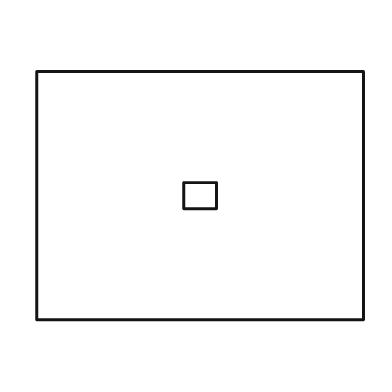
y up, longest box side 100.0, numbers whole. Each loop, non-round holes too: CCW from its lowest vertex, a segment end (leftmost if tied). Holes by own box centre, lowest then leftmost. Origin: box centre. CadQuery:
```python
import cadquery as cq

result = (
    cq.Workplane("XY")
    .moveTo(-50.0, -38.0)
    .lineTo(50.0, -38.0)
    .lineTo(50.0, 38.0)
    .lineTo(-50.0, 38.0)
    .close()
    .moveTo(-5.0, -4.0)
    .lineTo(5.0, -4.0)
    .lineTo(5.0, 4.0)
    .lineTo(-5.0, 4.0)
    .close()
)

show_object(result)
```